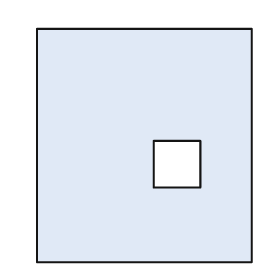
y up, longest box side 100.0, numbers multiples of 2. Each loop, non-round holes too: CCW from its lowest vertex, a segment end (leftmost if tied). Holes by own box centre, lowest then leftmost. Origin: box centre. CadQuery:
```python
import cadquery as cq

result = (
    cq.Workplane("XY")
    .moveTo(-46.0, -50.0)
    .lineTo(46.0, -50.0)
    .lineTo(46.0, 50.0)
    .lineTo(-46.0, 50.0)
    .close()
    .moveTo(4.0, -18.0)
    .lineTo(24.0, -18.0)
    .lineTo(24.0, 2.0)
    .lineTo(4.0, 2.0)
    .close()
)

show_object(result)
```